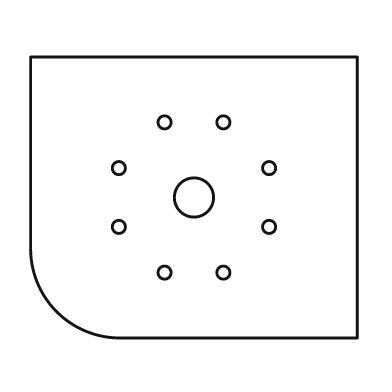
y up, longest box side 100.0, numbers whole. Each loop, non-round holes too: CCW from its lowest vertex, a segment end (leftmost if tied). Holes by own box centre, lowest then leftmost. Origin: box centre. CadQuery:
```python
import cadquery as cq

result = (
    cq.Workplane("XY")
    .moveTo(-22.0, -43.0)
    .lineTo(50.0, -43.0)
    .lineTo(50.0, 43.0)
    .lineTo(-50.0, 43.0)
    .lineTo(-50.0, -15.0)
    .threePointArc((-42.0, -35.0), (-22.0, -43.0))
    .close()
    .moveTo(-9.0, -23.0)
    .circle(2.0)
    .moveTo(9.0, -23.0)
    .circle(2.0)
    .moveTo(-23.0, -9.0)
    .circle(2.0)
    .moveTo(23.0, -9.0)
    .circle(2.0)
    .moveTo(0.0, 0.0)
    .circle(6.0)
    .moveTo(-23.0, 9.0)
    .circle(2.0)
    .moveTo(23.0, 9.0)
    .circle(2.0)
    .moveTo(-9.0, 23.0)
    .circle(2.0)
    .moveTo(9.0, 23.0)
    .circle(2.0)
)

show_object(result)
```